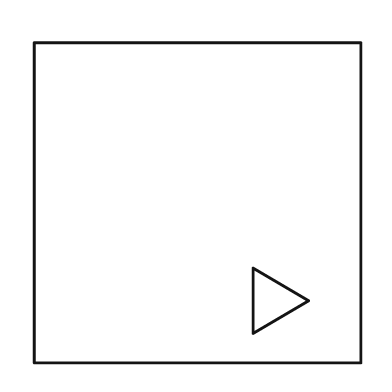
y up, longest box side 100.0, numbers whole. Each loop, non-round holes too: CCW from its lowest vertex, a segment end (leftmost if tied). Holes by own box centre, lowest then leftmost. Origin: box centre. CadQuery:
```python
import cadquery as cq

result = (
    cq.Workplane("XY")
    .moveTo(-50.0, -49.0)
    .lineTo(50.0, -49.0)
    .lineTo(50.0, 49.0)
    .lineTo(-50.0, 49.0)
    .close()
    .moveTo(17.0, -40.0)
    .lineTo(34.0, -30.0)
    .lineTo(17.0, -20.0)
    .close()
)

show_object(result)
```